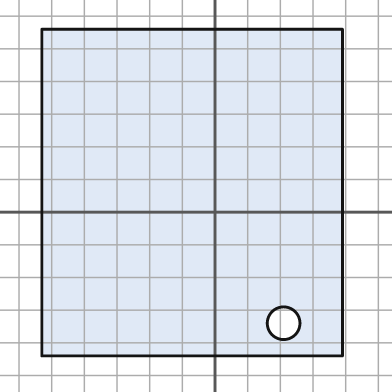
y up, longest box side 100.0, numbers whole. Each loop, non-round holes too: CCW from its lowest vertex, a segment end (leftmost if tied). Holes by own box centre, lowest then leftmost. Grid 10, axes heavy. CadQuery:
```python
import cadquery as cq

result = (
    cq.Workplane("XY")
    .moveTo(-53.0, -44.0)
    .lineTo(39.0, -44.0)
    .lineTo(39.0, 56.0)
    .lineTo(-53.0, 56.0)
    .close()
    .moveTo(21.0, -34.0)
    .circle(5.0)
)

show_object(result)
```